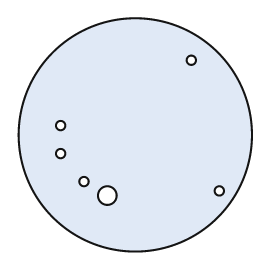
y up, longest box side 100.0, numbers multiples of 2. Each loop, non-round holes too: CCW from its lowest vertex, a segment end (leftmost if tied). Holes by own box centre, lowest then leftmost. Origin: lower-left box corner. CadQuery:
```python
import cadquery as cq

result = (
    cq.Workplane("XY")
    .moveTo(50.0, 50.0)
    .circle(50.0)
    .moveTo(38.0, 24.0)
    .circle(4.0)
    .moveTo(86.0, 26.0)
    .circle(2.0)
    .moveTo(28.0, 30.0)
    .circle(2.0)
    .moveTo(18.0, 42.0)
    .circle(2.0)
    .moveTo(18.0, 54.0)
    .circle(2.0)
    .moveTo(74.0, 82.0)
    .circle(2.0)
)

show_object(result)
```